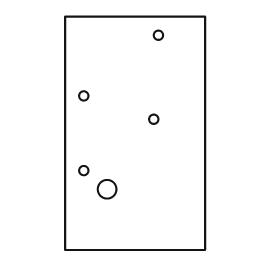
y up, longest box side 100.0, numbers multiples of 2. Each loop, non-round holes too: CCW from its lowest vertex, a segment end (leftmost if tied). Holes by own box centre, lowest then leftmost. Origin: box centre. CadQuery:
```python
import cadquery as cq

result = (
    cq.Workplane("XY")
    .moveTo(-30.0, -50.0)
    .lineTo(30.0, -50.0)
    .lineTo(30.0, 50.0)
    .lineTo(-30.0, 50.0)
    .close()
    .moveTo(-12.0, -24.0)
    .circle(4.0)
    .moveTo(-22.0, -16.0)
    .circle(2.0)
    .moveTo(8.0, 6.0)
    .circle(2.0)
    .moveTo(-22.0, 16.0)
    .circle(2.0)
    .moveTo(10.0, 42.0)
    .circle(2.0)
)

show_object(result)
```